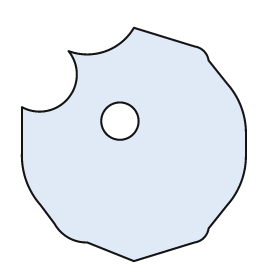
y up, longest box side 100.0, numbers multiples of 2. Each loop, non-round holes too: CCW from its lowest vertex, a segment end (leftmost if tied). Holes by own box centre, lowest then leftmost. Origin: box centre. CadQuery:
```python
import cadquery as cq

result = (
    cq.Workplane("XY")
    .moveTo(0.0, -50.0)
    .lineTo(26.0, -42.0)
    .threePointArc((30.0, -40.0), (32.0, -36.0))
    .lineTo(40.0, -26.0)
    .threePointArc((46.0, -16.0), (48.0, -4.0))
    .lineTo(48.0, 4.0)
    .threePointArc((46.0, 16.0), (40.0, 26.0))
    .lineTo(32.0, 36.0)
    .threePointArc((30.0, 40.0), (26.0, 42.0))
    .lineTo(0.0, 50.0)
    .threePointArc((-12.0, 40.0), (-28.0, 40.0))
    .threePointArc((-28.0, 20.0), (-48.0, 16.0))
    .lineTo(-48.0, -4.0)
    .threePointArc((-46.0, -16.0), (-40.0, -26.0))
    .lineTo(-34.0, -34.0)
    .threePointArc((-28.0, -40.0), (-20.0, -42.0))
    .close()
    .moveTo(-6.0, 10.0)
    .circle(8.0)
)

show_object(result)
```